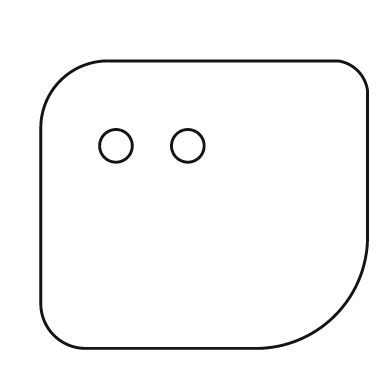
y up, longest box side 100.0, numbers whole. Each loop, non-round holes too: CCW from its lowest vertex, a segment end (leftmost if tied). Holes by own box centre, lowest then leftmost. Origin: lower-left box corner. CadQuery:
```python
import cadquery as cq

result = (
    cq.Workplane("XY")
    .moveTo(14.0, 0.0)
    .lineTo(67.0, 0.0)
    .threePointArc((90.0, 10.0), (100.0, 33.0))
    .lineTo(100.0, 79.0)
    .threePointArc((97.0, 85.0), (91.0, 88.0))
    .lineTo(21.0, 88.0)
    .threePointArc((6.0, 82.0), (0.0, 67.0))
    .lineTo(0.0, 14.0)
    .threePointArc((4.0, 4.0), (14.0, 0.0))
    .close()
    .moveTo(23.0, 62.0)
    .circle(5.0)
    .moveTo(45.0, 62.0)
    .circle(5.0)
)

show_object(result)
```